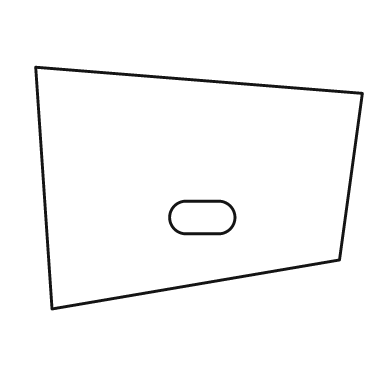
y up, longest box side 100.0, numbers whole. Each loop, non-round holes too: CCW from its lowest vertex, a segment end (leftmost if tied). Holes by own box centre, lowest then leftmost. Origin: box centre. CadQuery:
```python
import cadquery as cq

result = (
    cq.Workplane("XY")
    .moveTo(-45.0, -37.0)
    .lineTo(43.0, -22.0)
    .lineTo(50.0, 29.0)
    .lineTo(-50.0, 37.0)
    .close()
    .moveTo(-4.0, -14.0)
    .lineTo(6.0, -14.0)
    .threePointArc((11.0, -9.0), (6.0, -4.0))
    .lineTo(-4.0, -4.0)
    .threePointArc((-9.0, -9.0), (-4.0, -14.0))
    .close()
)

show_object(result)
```